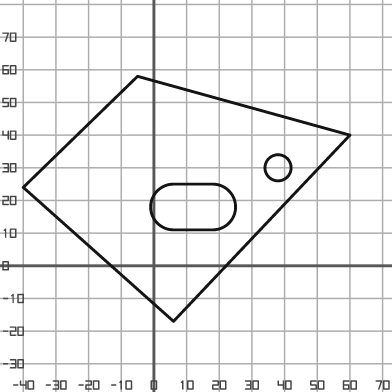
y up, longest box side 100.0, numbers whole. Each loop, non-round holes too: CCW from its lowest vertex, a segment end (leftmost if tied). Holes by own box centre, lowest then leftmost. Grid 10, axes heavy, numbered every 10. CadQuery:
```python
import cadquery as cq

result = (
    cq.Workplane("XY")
    .moveTo(6.0, -17.0)
    .lineTo(60.0, 40.0)
    .lineTo(-5.0, 58.0)
    .lineTo(-40.0, 24.0)
    .close()
    .moveTo(6.0, 11.0)
    .lineTo(18.0, 11.0)
    .threePointArc((25.0, 18.0), (18.0, 25.0))
    .lineTo(6.0, 25.0)
    .threePointArc((-1.0, 18.0), (6.0, 11.0))
    .close()
    .moveTo(38.0, 30.0)
    .circle(4.0)
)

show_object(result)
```